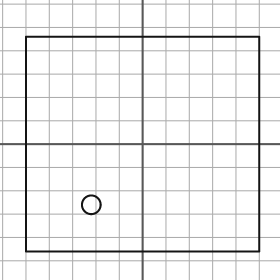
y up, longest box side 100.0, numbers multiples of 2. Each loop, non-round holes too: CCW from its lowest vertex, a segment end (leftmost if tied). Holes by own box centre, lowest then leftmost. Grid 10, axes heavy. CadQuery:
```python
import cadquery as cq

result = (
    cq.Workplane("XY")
    .moveTo(-50.0, -46.0)
    .lineTo(50.0, -46.0)
    .lineTo(50.0, 46.0)
    .lineTo(-50.0, 46.0)
    .close()
    .moveTo(-22.0, -26.0)
    .circle(4.0)
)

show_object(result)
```